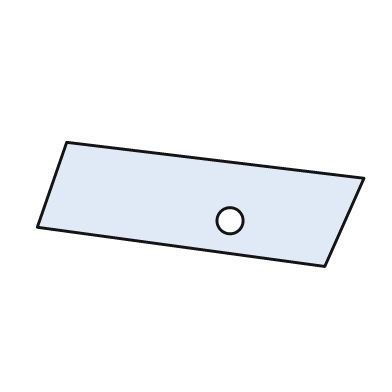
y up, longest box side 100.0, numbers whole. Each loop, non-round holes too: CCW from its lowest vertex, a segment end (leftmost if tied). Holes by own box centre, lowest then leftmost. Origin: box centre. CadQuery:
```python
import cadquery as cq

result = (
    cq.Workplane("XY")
    .moveTo(38.0, -19.0)
    .lineTo(50.0, 8.0)
    .lineTo(-41.0, 19.0)
    .lineTo(-50.0, -7.0)
    .close()
    .moveTo(9.0, -5.0)
    .circle(4.0)
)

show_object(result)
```